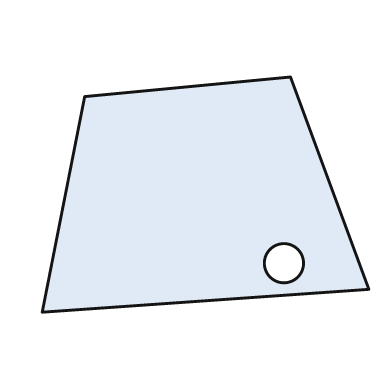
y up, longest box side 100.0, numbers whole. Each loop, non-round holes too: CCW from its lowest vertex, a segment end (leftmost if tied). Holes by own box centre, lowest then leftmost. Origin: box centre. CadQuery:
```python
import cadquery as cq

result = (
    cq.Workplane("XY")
    .moveTo(-50.0, -36.0)
    .lineTo(50.0, -29.0)
    .lineTo(26.0, 36.0)
    .lineTo(-37.0, 30.0)
    .close()
    .moveTo(24.0, -21.0)
    .circle(6.0)
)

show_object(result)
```